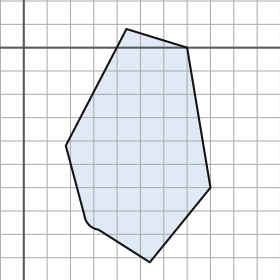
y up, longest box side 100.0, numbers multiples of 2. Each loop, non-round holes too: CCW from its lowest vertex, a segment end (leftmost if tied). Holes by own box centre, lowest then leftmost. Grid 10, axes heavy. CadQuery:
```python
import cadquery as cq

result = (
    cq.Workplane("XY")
    .moveTo(54.0, -92.0)
    .lineTo(80.0, -60.0)
    .lineTo(70.0, 0.0)
    .lineTo(44.0, 8.0)
    .lineTo(18.0, -42.0)
    .lineTo(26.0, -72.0)
    .threePointArc((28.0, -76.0), (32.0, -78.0))
    .close()
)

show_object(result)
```